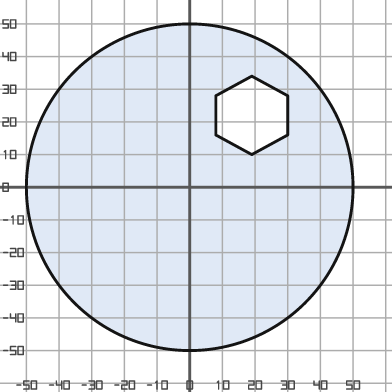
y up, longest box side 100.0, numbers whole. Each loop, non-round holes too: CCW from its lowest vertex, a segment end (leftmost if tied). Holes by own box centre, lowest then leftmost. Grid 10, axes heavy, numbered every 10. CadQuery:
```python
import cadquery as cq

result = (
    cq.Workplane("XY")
    .moveTo(0.0, 0.0)
    .circle(50.0)
    .moveTo(19.0, 10.0)
    .lineTo(30.0, 16.0)
    .lineTo(30.0, 28.0)
    .lineTo(19.0, 34.0)
    .lineTo(8.0, 28.0)
    .lineTo(8.0, 16.0)
    .close()
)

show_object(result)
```